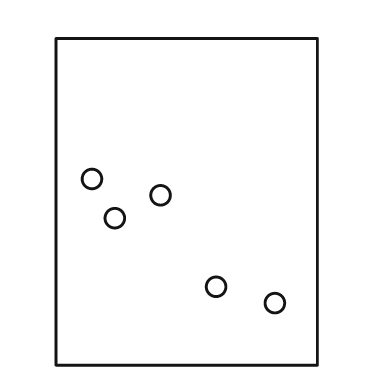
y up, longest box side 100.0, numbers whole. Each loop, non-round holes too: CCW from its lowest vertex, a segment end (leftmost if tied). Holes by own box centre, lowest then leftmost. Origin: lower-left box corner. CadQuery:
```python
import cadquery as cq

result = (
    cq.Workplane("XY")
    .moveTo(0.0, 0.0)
    .lineTo(80.0, 0.0)
    .lineTo(80.0, 100.0)
    .lineTo(0.0, 100.0)
    .close()
    .moveTo(67.0, 19.0)
    .circle(3.0)
    .moveTo(49.0, 24.0)
    .circle(3.0)
    .moveTo(18.0, 45.0)
    .circle(3.0)
    .moveTo(32.0, 52.0)
    .circle(3.0)
    .moveTo(11.0, 57.0)
    .circle(3.0)
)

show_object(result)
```